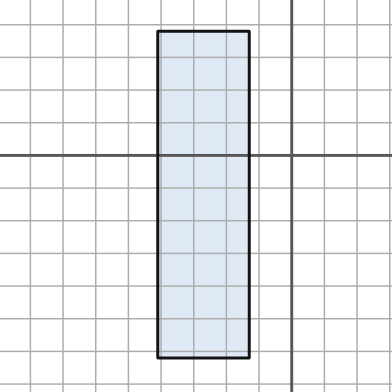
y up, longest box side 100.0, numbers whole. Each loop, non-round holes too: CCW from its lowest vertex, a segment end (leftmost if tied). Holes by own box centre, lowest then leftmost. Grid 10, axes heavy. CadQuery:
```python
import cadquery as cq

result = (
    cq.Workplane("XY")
    .moveTo(-41.0, -62.0)
    .lineTo(-13.0, -62.0)
    .lineTo(-13.0, 38.0)
    .lineTo(-41.0, 38.0)
    .close()
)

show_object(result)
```